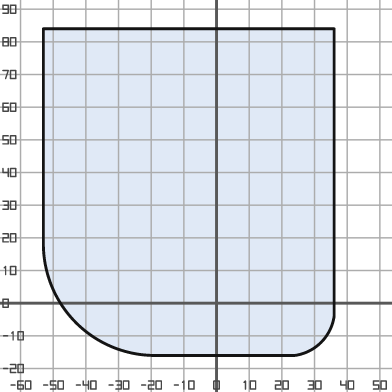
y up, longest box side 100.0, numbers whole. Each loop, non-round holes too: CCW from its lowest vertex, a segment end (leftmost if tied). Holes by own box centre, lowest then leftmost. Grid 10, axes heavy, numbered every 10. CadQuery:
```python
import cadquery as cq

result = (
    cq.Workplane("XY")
    .moveTo(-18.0, -16.0)
    .lineTo(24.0, -16.0)
    .threePointArc((32.0, -12.0), (36.0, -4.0))
    .lineTo(36.0, 84.0)
    .lineTo(-53.0, 84.0)
    .lineTo(-53.0, 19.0)
    .threePointArc((-43.0, -6.0), (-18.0, -16.0))
    .close()
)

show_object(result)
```